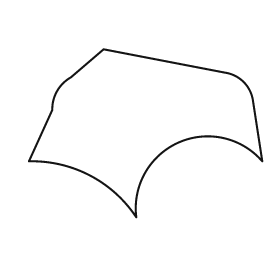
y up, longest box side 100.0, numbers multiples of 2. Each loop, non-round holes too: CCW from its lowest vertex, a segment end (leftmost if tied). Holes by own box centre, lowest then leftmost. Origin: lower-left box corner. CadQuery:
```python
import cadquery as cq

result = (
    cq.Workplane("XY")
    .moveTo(46.0, 0.0)
    .threePointArc((64.0, 32.0), (100.0, 24.0))
    .lineTo(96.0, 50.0)
    .threePointArc((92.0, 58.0), (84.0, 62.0))
    .lineTo(32.0, 72.0)
    .lineTo(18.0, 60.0)
    .threePointArc((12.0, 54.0), (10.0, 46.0))
    .lineTo(0.0, 24.0)
    .threePointArc((26.0, 18.0), (46.0, 0.0))
    .close()
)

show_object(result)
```